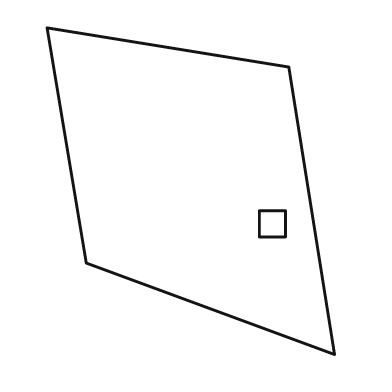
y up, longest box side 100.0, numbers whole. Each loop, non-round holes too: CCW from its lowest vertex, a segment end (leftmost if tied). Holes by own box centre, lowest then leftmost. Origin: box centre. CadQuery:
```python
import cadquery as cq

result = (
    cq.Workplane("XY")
    .moveTo(44.0, -50.0)
    .lineTo(30.0, 38.0)
    .lineTo(-44.0, 50.0)
    .lineTo(-32.0, -22.0)
    .close()
    .moveTo(21.0, -14.0)
    .lineTo(29.0, -14.0)
    .lineTo(29.0, -6.0)
    .lineTo(21.0, -6.0)
    .close()
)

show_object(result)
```